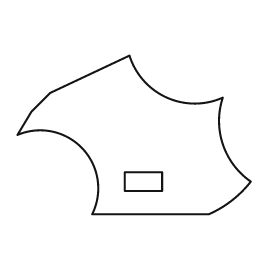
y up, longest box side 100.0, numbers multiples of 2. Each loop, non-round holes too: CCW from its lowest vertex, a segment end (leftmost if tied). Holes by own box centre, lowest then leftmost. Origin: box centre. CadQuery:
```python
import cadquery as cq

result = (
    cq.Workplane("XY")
    .moveTo(-18.0, -34.0)
    .lineTo(32.0, -34.0)
    .threePointArc((42.0, -28.0), (50.0, -20.0))
    .threePointArc((38.0, -4.0), (38.0, 16.0))
    .threePointArc((14.0, 16.0), (-2.0, 34.0))
    .lineTo(-36.0, 18.0)
    .lineTo(-44.0, 10.0)
    .lineTo(-50.0, 0.0)
    .threePointArc((-22.0, -6.0), (-18.0, -34.0))
    .close()
    .moveTo(-4.0, -24.0)
    .lineTo(12.0, -24.0)
    .lineTo(12.0, -16.0)
    .lineTo(-4.0, -16.0)
    .close()
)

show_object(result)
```